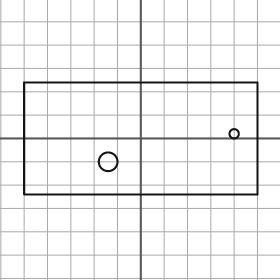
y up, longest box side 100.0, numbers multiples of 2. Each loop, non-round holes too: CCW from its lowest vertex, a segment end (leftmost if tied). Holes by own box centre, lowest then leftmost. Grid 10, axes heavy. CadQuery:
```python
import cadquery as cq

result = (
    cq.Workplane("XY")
    .moveTo(-50.0, -24.0)
    .lineTo(50.0, -24.0)
    .lineTo(50.0, 24.0)
    .lineTo(-50.0, 24.0)
    .close()
    .moveTo(-14.0, -10.0)
    .circle(4.0)
    .moveTo(40.0, 2.0)
    .circle(2.0)
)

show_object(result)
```